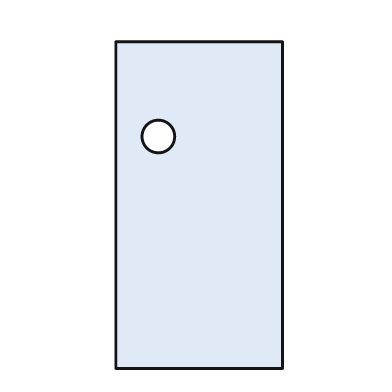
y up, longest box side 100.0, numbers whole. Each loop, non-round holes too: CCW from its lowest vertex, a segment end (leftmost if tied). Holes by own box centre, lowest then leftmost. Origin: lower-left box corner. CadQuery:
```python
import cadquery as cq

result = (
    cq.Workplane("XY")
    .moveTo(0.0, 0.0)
    .lineTo(51.0, 0.0)
    .lineTo(51.0, 100.0)
    .lineTo(0.0, 100.0)
    .close()
    .moveTo(13.0, 71.0)
    .circle(5.0)
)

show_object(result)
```